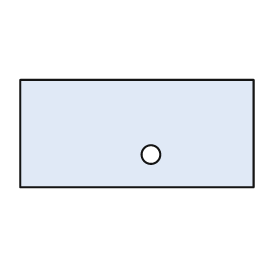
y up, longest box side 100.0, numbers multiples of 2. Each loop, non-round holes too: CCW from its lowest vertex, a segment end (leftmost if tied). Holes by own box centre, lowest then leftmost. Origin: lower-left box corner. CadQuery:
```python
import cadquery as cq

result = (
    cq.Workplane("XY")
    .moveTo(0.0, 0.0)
    .lineTo(100.0, 0.0)
    .lineTo(100.0, 46.0)
    .lineTo(0.0, 46.0)
    .close()
    .moveTo(56.0, 14.0)
    .circle(4.0)
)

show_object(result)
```